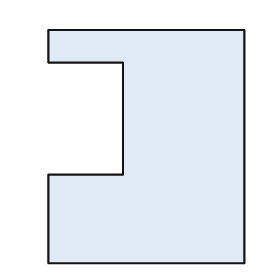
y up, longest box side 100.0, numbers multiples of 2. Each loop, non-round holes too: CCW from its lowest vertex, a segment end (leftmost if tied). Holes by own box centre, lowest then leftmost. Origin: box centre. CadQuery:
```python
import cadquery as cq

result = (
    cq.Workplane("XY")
    .moveTo(-42.0, -50.0)
    .lineTo(42.0, -50.0)
    .lineTo(42.0, 50.0)
    .lineTo(-42.0, 50.0)
    .lineTo(-42.0, 36.0)
    .lineTo(-10.0, 36.0)
    .lineTo(-10.0, -12.0)
    .lineTo(-42.0, -12.0)
    .close()
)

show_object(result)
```